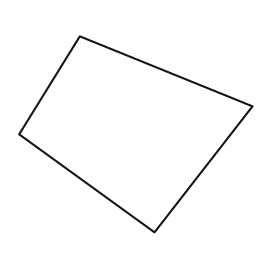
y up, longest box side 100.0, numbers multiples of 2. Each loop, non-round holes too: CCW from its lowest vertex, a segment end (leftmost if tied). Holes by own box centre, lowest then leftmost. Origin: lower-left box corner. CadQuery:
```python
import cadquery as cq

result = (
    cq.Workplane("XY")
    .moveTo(58.0, 0.0)
    .lineTo(100.0, 54.0)
    .lineTo(26.0, 84.0)
    .lineTo(0.0, 42.0)
    .close()
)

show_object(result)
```